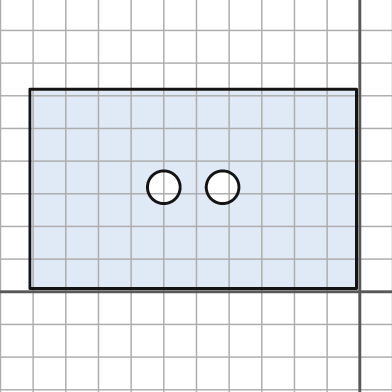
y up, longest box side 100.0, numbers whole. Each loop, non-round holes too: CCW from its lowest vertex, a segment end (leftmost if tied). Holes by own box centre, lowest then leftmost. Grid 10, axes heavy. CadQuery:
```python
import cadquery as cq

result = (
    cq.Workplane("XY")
    .moveTo(-101.0, 1.0)
    .lineTo(-1.0, 1.0)
    .lineTo(-1.0, 62.0)
    .lineTo(-101.0, 62.0)
    .close()
    .moveTo(-60.0, 32.0)
    .circle(5.0)
    .moveTo(-42.0, 32.0)
    .circle(5.0)
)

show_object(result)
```